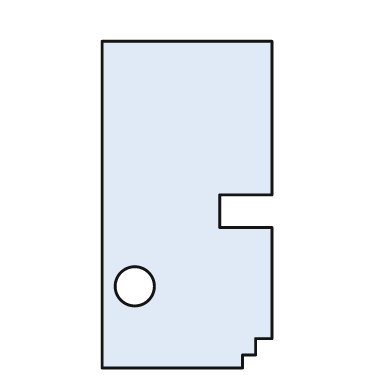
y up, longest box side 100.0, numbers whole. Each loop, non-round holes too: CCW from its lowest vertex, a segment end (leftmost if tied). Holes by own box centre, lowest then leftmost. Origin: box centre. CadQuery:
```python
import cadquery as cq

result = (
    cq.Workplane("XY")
    .moveTo(-26.0, -50.0)
    .lineTo(17.0, -50.0)
    .lineTo(17.0, -46.0)
    .lineTo(21.0, -46.0)
    .lineTo(21.0, -41.0)
    .lineTo(26.0, -41.0)
    .lineTo(26.0, -7.0)
    .lineTo(10.0, -7.0)
    .lineTo(10.0, 3.0)
    .lineTo(26.0, 3.0)
    .lineTo(26.0, 50.0)
    .lineTo(-26.0, 50.0)
    .close()
    .moveTo(-16.0, -25.0)
    .circle(6.0)
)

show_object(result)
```